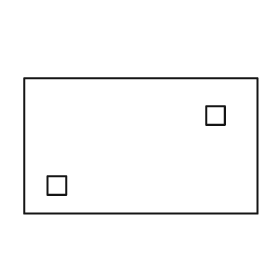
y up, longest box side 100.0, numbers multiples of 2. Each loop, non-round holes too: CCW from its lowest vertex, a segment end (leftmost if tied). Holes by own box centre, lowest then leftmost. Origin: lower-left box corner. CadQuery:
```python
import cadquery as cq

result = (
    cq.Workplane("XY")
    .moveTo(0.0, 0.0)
    .lineTo(100.0, 0.0)
    .lineTo(100.0, 58.0)
    .lineTo(0.0, 58.0)
    .close()
    .moveTo(10.0, 8.0)
    .lineTo(18.0, 8.0)
    .lineTo(18.0, 16.0)
    .lineTo(10.0, 16.0)
    .close()
    .moveTo(78.0, 38.0)
    .lineTo(86.0, 38.0)
    .lineTo(86.0, 46.0)
    .lineTo(78.0, 46.0)
    .close()
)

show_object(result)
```